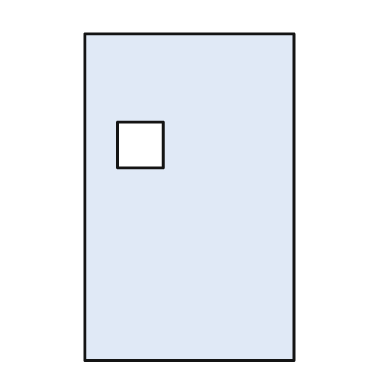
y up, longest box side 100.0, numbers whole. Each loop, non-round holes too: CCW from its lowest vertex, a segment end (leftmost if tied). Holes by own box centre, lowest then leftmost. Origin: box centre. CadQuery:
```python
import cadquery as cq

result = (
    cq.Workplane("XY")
    .moveTo(-32.0, -50.0)
    .lineTo(32.0, -50.0)
    .lineTo(32.0, 50.0)
    .lineTo(-32.0, 50.0)
    .close()
    .moveTo(-22.0, 9.0)
    .lineTo(-8.0, 9.0)
    .lineTo(-8.0, 23.0)
    .lineTo(-22.0, 23.0)
    .close()
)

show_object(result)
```